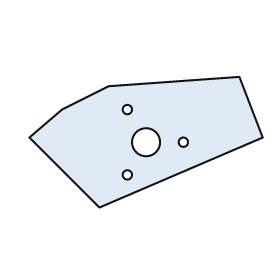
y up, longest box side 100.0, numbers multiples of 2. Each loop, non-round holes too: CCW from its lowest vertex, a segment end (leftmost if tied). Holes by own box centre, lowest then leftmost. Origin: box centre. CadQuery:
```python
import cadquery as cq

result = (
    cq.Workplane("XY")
    .moveTo(-20.0, -28.0)
    .lineTo(50.0, 2.0)
    .lineTo(40.0, 28.0)
    .lineTo(-16.0, 24.0)
    .lineTo(-36.0, 14.0)
    .lineTo(-50.0, 2.0)
    .close()
    .moveTo(-8.0, -14.0)
    .circle(2.0)
    .moveTo(0.0, 0.0)
    .circle(6.0)
    .moveTo(16.0, 0.0)
    .circle(2.0)
    .moveTo(-8.0, 14.0)
    .circle(2.0)
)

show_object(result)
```